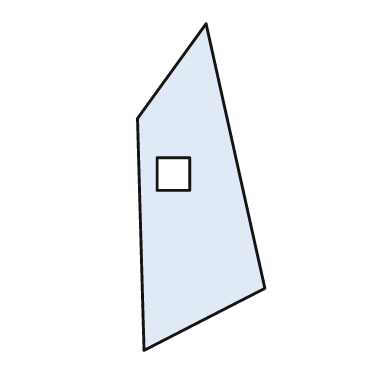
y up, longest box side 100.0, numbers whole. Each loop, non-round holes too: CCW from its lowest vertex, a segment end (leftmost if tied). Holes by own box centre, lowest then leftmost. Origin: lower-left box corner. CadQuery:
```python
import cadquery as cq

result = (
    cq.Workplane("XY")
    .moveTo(2.0, 0.0)
    .lineTo(39.0, 19.0)
    .lineTo(21.0, 100.0)
    .lineTo(0.0, 71.0)
    .close()
    .moveTo(6.0, 49.0)
    .lineTo(16.0, 49.0)
    .lineTo(16.0, 59.0)
    .lineTo(6.0, 59.0)
    .close()
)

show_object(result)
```